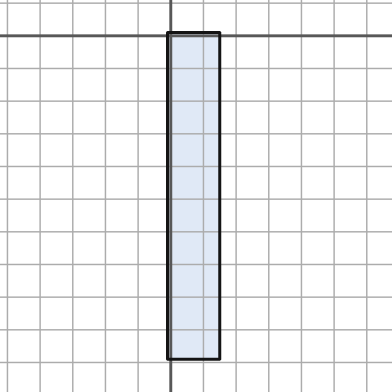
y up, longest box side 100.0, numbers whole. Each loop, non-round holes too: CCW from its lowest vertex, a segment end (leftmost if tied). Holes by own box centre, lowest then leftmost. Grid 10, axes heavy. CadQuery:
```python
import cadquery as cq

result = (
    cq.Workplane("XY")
    .moveTo(-1.0, -99.0)
    .lineTo(15.0, -99.0)
    .lineTo(15.0, 1.0)
    .lineTo(-1.0, 1.0)
    .close()
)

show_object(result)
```